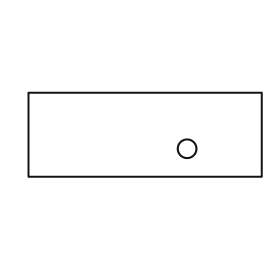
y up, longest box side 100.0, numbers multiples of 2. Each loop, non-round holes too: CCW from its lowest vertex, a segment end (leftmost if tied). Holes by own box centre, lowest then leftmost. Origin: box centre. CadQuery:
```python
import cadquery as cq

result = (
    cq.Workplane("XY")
    .moveTo(-50.0, -18.0)
    .lineTo(50.0, -18.0)
    .lineTo(50.0, 18.0)
    .lineTo(-50.0, 18.0)
    .close()
    .moveTo(18.0, -6.0)
    .circle(4.0)
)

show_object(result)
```